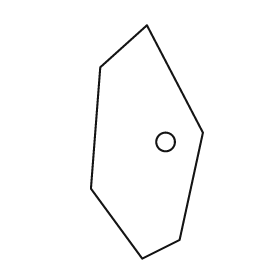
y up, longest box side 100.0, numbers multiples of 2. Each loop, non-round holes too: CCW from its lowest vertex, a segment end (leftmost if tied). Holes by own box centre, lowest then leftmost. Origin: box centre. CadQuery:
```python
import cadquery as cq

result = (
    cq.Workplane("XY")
    .moveTo(-2.0, -50.0)
    .lineTo(14.0, -42.0)
    .lineTo(24.0, 4.0)
    .lineTo(0.0, 50.0)
    .lineTo(-20.0, 32.0)
    .lineTo(-24.0, -20.0)
    .close()
    .moveTo(8.0, 0.0)
    .circle(4.0)
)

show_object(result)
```